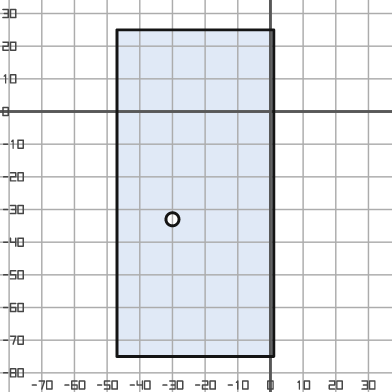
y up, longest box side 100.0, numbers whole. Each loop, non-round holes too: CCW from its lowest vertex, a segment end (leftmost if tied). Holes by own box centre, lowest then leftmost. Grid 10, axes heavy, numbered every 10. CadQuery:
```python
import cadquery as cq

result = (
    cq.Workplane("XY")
    .moveTo(-47.0, -75.0)
    .lineTo(1.0, -75.0)
    .lineTo(1.0, 25.0)
    .lineTo(-47.0, 25.0)
    .close()
    .moveTo(-30.0, -33.0)
    .circle(2.0)
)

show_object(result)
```